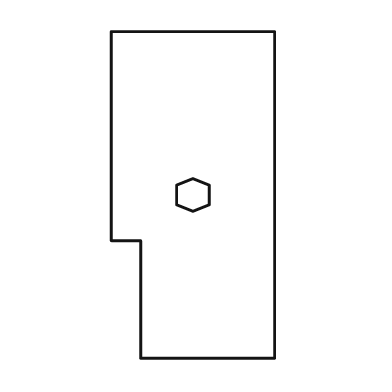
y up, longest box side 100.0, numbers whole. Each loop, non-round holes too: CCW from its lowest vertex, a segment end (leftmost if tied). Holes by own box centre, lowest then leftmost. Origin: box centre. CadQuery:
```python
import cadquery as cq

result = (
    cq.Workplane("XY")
    .moveTo(-16.0, -50.0)
    .lineTo(25.0, -50.0)
    .lineTo(25.0, 50.0)
    .lineTo(-25.0, 50.0)
    .lineTo(-25.0, -14.0)
    .lineTo(-16.0, -14.0)
    .close()
    .moveTo(0.0, -5.0)
    .lineTo(5.0, -3.0)
    .lineTo(5.0, 3.0)
    .lineTo(0.0, 5.0)
    .lineTo(-5.0, 3.0)
    .lineTo(-5.0, -3.0)
    .close()
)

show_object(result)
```